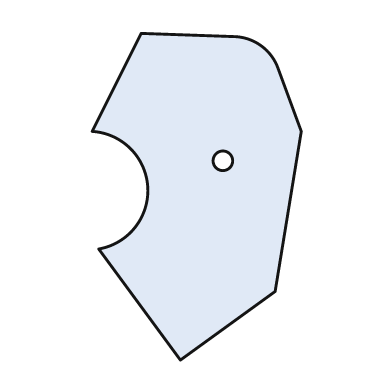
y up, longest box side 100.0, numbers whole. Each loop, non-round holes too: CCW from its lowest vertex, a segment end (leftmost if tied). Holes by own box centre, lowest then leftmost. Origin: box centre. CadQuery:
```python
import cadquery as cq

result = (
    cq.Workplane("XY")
    .moveTo(-5.0, -50.0)
    .lineTo(24.0, -29.0)
    .lineTo(32.0, 20.0)
    .lineTo(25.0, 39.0)
    .threePointArc((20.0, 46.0), (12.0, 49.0))
    .lineTo(-17.0, 50.0)
    .lineTo(-32.0, 20.0)
    .threePointArc((-15.0, 3.0), (-30.0, -16.0))
    .close()
    .moveTo(8.0, 11.0)
    .circle(3.0)
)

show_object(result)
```